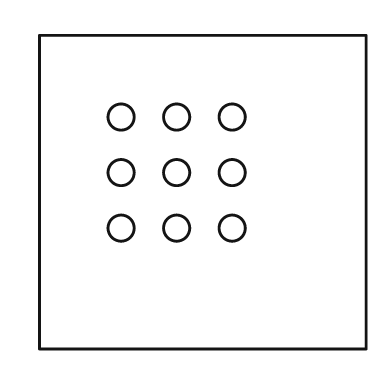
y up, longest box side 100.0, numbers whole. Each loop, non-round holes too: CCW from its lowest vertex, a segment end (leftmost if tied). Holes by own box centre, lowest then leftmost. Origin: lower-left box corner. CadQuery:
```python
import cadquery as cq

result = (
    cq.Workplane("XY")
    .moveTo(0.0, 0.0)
    .lineTo(100.0, 0.0)
    .lineTo(100.0, 96.0)
    .lineTo(0.0, 96.0)
    .close()
    .moveTo(25.0, 37.0)
    .circle(4.0)
    .moveTo(42.0, 37.0)
    .circle(4.0)
    .moveTo(59.0, 37.0)
    .circle(4.0)
    .moveTo(25.0, 54.0)
    .circle(4.0)
    .moveTo(42.0, 54.0)
    .circle(4.0)
    .moveTo(59.0, 54.0)
    .circle(4.0)
    .moveTo(25.0, 71.0)
    .circle(4.0)
    .moveTo(42.0, 71.0)
    .circle(4.0)
    .moveTo(59.0, 71.0)
    .circle(4.0)
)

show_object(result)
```